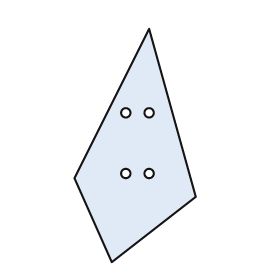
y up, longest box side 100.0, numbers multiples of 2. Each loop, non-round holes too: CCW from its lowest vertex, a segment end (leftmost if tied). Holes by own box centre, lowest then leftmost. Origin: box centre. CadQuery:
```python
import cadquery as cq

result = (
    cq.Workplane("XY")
    .moveTo(-10.0, -50.0)
    .lineTo(26.0, -22.0)
    .lineTo(6.0, 50.0)
    .lineTo(-26.0, -14.0)
    .close()
    .moveTo(-4.0, -12.0)
    .circle(2.0)
    .moveTo(6.0, -12.0)
    .circle(2.0)
    .moveTo(-4.0, 14.0)
    .circle(2.0)
    .moveTo(6.0, 14.0)
    .circle(2.0)
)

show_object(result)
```